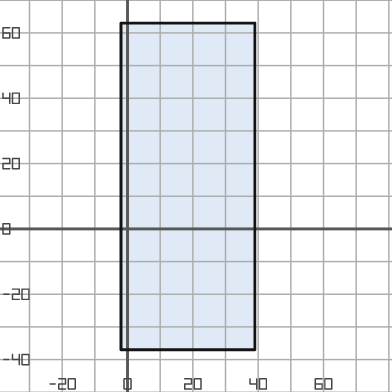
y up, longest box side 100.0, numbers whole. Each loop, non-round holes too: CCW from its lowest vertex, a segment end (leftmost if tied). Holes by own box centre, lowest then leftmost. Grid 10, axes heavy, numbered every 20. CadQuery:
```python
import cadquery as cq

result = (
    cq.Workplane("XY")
    .moveTo(-2.0, -37.0)
    .lineTo(39.0, -37.0)
    .lineTo(39.0, 63.0)
    .lineTo(-2.0, 63.0)
    .close()
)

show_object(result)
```